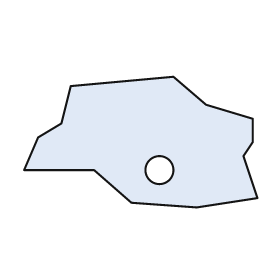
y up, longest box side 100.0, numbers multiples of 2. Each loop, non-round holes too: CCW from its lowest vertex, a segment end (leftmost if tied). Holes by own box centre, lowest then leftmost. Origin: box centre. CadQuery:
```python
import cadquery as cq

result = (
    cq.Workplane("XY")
    .moveTo(24.0, -28.0)
    .lineTo(50.0, -24.0)
    .lineTo(44.0, -6.0)
    .lineTo(48.0, 0.0)
    .lineTo(48.0, 10.0)
    .lineTo(28.0, 16.0)
    .lineTo(14.0, 28.0)
    .lineTo(-30.0, 24.0)
    .lineTo(-34.0, 8.0)
    .lineTo(-44.0, 2.0)
    .lineTo(-50.0, -12.0)
    .lineTo(-20.0, -12.0)
    .lineTo(-4.0, -26.0)
    .close()
    .moveTo(8.0, -12.0)
    .circle(6.0)
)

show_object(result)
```